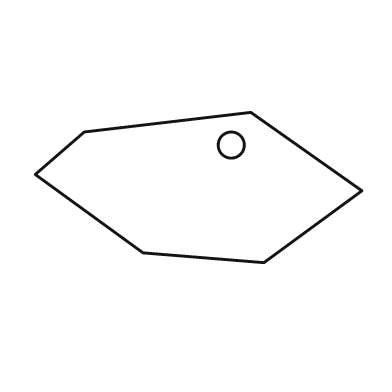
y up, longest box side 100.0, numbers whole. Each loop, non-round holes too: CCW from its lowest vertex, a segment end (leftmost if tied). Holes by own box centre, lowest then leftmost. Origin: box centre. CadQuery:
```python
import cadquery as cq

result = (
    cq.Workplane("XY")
    .moveTo(20.0, -23.0)
    .lineTo(50.0, -1.0)
    .lineTo(16.0, 23.0)
    .lineTo(-35.0, 17.0)
    .lineTo(-50.0, 4.0)
    .lineTo(-17.0, -20.0)
    .close()
    .moveTo(10.0, 13.0)
    .circle(4.0)
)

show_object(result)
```